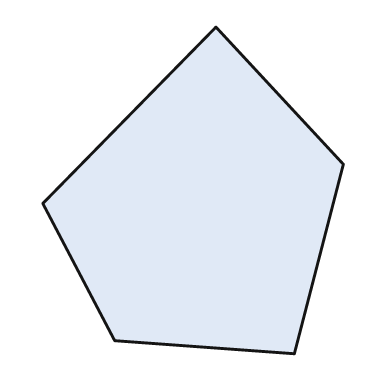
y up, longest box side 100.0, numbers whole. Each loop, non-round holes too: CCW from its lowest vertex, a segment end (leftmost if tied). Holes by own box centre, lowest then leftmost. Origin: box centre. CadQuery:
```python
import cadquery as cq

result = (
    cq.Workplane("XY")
    .moveTo(31.0, -50.0)
    .lineTo(46.0, 8.0)
    .lineTo(7.0, 50.0)
    .lineTo(-46.0, -4.0)
    .lineTo(-24.0, -46.0)
    .close()
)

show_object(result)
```